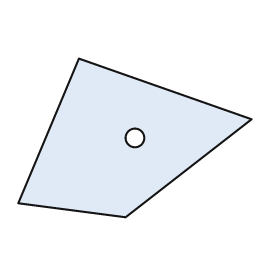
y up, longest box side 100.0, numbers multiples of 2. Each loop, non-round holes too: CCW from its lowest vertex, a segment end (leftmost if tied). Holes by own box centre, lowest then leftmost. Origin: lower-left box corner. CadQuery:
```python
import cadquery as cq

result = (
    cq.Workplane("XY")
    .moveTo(46.0, 0.0)
    .lineTo(100.0, 42.0)
    .lineTo(26.0, 68.0)
    .lineTo(0.0, 6.0)
    .close()
    .moveTo(50.0, 34.0)
    .circle(4.0)
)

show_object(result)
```